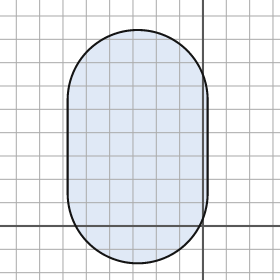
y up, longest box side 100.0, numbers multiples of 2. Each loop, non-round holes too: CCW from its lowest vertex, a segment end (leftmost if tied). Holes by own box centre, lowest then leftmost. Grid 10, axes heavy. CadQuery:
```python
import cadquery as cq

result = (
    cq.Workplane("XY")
    .moveTo(-58.0, 14.0)
    .threePointArc((-28.0, -16.0), (2.0, 14.0))
    .lineTo(2.0, 54.0)
    .threePointArc((-28.0, 84.0), (-58.0, 54.0))
    .close()
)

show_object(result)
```